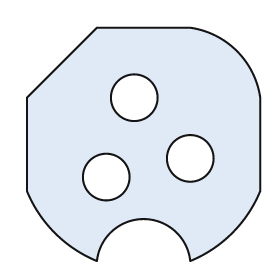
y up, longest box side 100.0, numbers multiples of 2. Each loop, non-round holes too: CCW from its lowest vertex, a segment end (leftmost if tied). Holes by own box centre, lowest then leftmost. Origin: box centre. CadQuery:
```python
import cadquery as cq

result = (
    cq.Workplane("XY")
    .moveTo(-20.0, -50.0)
    .threePointArc((0.0, -32.0), (20.0, -50.0))
    .threePointArc((38.0, -38.0), (50.0, -20.0))
    .lineTo(50.0, 20.0)
    .threePointArc((40.0, 40.0), (20.0, 50.0))
    .lineTo(-20.0, 50.0)
    .lineTo(-50.0, 20.0)
    .lineTo(-50.0, -20.0)
    .threePointArc((-38.0, -38.0), (-20.0, -50.0))
    .close()
    .moveTo(-16.0, -14.0)
    .circle(10.0)
    .moveTo(20.0, -6.0)
    .circle(10.0)
    .moveTo(-4.0, 20.0)
    .circle(10.0)
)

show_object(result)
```